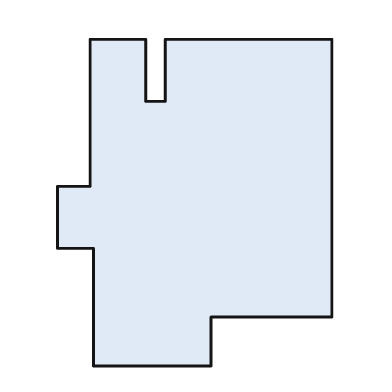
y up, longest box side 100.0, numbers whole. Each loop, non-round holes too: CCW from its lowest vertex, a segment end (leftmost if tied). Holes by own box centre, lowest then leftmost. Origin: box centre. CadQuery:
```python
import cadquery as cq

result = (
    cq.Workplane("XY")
    .moveTo(-31.0, -50.0)
    .lineTo(5.0, -50.0)
    .lineTo(5.0, -35.0)
    .lineTo(42.0, -35.0)
    .lineTo(42.0, 50.0)
    .lineTo(-9.0, 50.0)
    .lineTo(-9.0, 31.0)
    .lineTo(-15.0, 31.0)
    .lineTo(-15.0, 50.0)
    .lineTo(-32.0, 50.0)
    .lineTo(-32.0, 5.0)
    .lineTo(-42.0, 5.0)
    .lineTo(-42.0, -14.0)
    .lineTo(-31.0, -14.0)
    .close()
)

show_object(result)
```